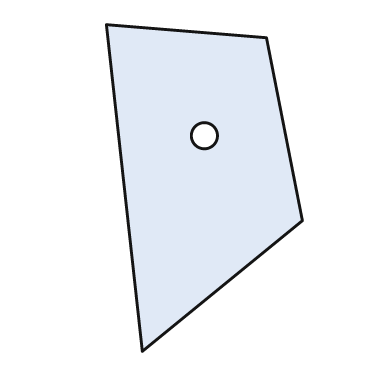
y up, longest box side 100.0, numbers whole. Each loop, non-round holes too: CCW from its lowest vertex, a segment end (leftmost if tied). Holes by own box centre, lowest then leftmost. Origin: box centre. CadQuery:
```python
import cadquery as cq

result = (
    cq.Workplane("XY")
    .moveTo(-19.0, -50.0)
    .lineTo(30.0, -10.0)
    .lineTo(19.0, 46.0)
    .lineTo(-30.0, 50.0)
    .close()
    .moveTo(0.0, 16.0)
    .circle(4.0)
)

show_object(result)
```